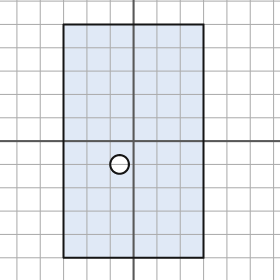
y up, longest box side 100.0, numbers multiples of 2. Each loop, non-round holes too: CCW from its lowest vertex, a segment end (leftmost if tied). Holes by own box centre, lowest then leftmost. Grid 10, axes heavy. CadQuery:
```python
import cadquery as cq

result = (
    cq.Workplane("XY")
    .moveTo(-30.0, -50.0)
    .lineTo(30.0, -50.0)
    .lineTo(30.0, 50.0)
    .lineTo(-30.0, 50.0)
    .close()
    .moveTo(-6.0, -10.0)
    .circle(4.0)
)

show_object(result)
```